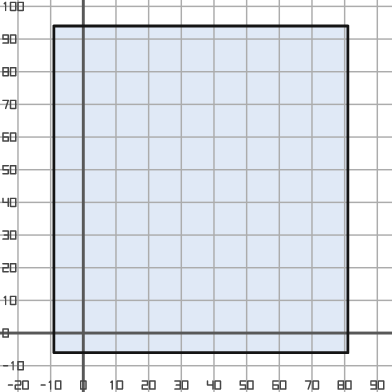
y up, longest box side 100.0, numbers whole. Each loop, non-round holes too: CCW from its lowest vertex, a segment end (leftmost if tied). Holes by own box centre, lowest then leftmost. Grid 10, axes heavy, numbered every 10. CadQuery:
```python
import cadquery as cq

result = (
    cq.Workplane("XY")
    .moveTo(-9.0, -6.0)
    .lineTo(81.0, -6.0)
    .lineTo(81.0, 94.0)
    .lineTo(-9.0, 94.0)
    .close()
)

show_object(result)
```